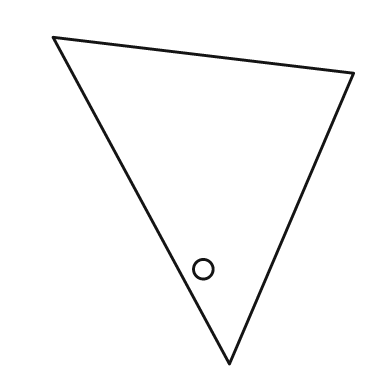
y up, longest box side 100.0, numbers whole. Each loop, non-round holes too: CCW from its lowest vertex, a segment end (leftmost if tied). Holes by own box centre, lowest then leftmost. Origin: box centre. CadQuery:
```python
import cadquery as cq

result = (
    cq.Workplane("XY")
    .moveTo(8.0, -50.0)
    .lineTo(46.0, 39.0)
    .lineTo(-46.0, 50.0)
    .close()
    .moveTo(0.0, -21.0)
    .circle(3.0)
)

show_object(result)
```